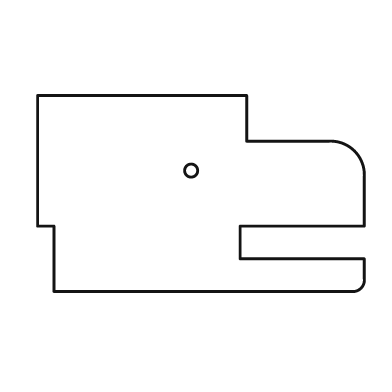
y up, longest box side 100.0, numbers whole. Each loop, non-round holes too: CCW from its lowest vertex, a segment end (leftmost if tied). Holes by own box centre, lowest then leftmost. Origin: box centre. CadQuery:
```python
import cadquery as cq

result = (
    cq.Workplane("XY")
    .moveTo(-45.0, -30.0)
    .lineTo(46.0, -30.0)
    .threePointArc((49.0, -29.0), (50.0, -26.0))
    .lineTo(50.0, -20.0)
    .lineTo(12.0, -20.0)
    .lineTo(12.0, -10.0)
    .lineTo(50.0, -10.0)
    .lineTo(50.0, 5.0)
    .threePointArc((47.0, 13.0), (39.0, 16.0))
    .lineTo(14.0, 16.0)
    .lineTo(14.0, 30.0)
    .lineTo(-50.0, 30.0)
    .lineTo(-50.0, -10.0)
    .lineTo(-45.0, -10.0)
    .close()
    .moveTo(-3.0, 7.0)
    .circle(2.0)
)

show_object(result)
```